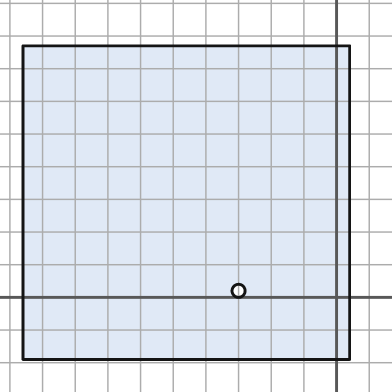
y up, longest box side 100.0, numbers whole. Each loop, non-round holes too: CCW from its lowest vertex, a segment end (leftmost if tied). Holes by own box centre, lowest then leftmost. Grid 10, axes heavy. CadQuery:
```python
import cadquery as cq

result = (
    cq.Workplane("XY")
    .moveTo(-96.0, -19.0)
    .lineTo(4.0, -19.0)
    .lineTo(4.0, 77.0)
    .lineTo(-96.0, 77.0)
    .close()
    .moveTo(-30.0, 2.0)
    .circle(2.0)
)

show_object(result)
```